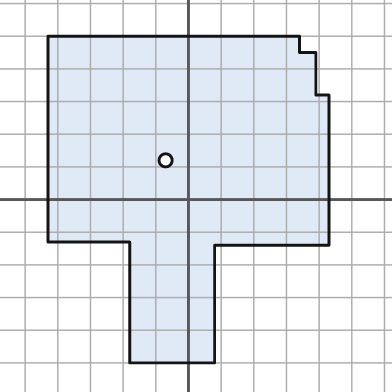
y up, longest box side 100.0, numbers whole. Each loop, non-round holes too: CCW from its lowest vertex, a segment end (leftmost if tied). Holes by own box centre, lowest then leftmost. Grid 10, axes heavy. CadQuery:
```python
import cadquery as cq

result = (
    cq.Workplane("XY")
    .moveTo(-18.0, -50.0)
    .lineTo(8.0, -50.0)
    .lineTo(8.0, -14.0)
    .lineTo(43.0, -14.0)
    .lineTo(43.0, 32.0)
    .lineTo(39.0, 32.0)
    .lineTo(39.0, 45.0)
    .lineTo(34.0, 45.0)
    .lineTo(34.0, 50.0)
    .lineTo(-43.0, 50.0)
    .lineTo(-43.0, -13.0)
    .lineTo(-18.0, -13.0)
    .close()
    .moveTo(-7.0, 12.0)
    .circle(2.0)
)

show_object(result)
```